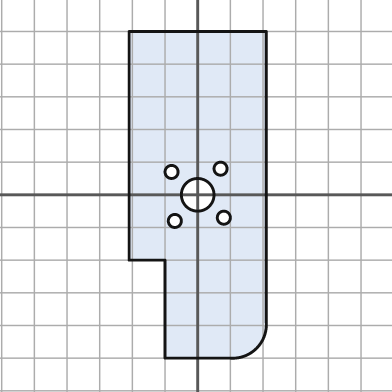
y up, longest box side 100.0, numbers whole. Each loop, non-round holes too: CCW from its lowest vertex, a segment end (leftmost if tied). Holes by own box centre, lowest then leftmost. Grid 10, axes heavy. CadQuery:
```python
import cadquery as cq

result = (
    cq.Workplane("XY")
    .moveTo(-10.0, -50.0)
    .lineTo(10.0, -50.0)
    .threePointArc((18.0, -47.0), (21.0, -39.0))
    .lineTo(21.0, 50.0)
    .lineTo(-21.0, 50.0)
    .lineTo(-21.0, -20.0)
    .lineTo(-10.0, -20.0)
    .close()
    .moveTo(-7.0, -8.0)
    .circle(2.0)
    .moveTo(8.0, -7.0)
    .circle(2.0)
    .moveTo(0.0, 0.0)
    .circle(5.0)
    .moveTo(-8.0, 7.0)
    .circle(2.0)
    .moveTo(7.0, 8.0)
    .circle(2.0)
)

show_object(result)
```